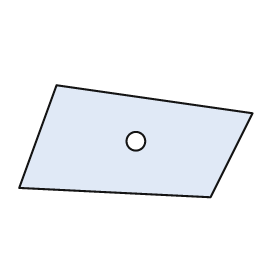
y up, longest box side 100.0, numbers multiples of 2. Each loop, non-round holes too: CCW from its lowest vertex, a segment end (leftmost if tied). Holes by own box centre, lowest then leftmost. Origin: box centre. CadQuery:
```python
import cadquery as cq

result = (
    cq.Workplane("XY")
    .moveTo(32.0, -24.0)
    .lineTo(50.0, 12.0)
    .lineTo(-34.0, 24.0)
    .lineTo(-50.0, -20.0)
    .close()
    .moveTo(0.0, 0.0)
    .circle(4.0)
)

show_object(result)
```